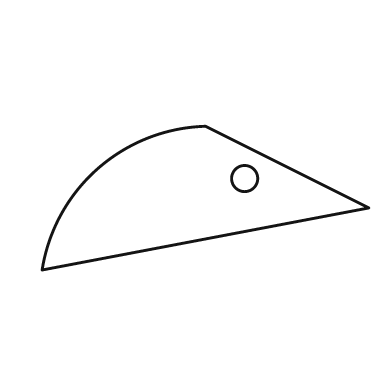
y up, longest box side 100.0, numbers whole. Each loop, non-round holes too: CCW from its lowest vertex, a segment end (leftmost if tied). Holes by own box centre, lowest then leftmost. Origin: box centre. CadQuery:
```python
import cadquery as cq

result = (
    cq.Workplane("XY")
    .moveTo(-50.0, -22.0)
    .lineTo(50.0, -3.0)
    .lineTo(0.0, 22.0)
    .threePointArc((-33.0, 9.0), (-50.0, -22.0))
    .close()
    .moveTo(12.0, 6.0)
    .circle(4.0)
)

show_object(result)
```